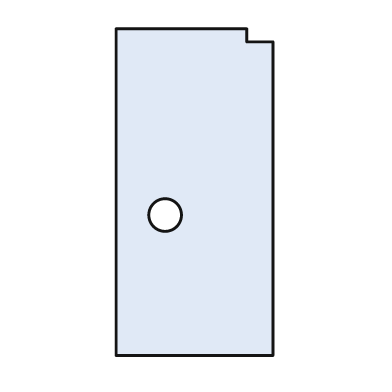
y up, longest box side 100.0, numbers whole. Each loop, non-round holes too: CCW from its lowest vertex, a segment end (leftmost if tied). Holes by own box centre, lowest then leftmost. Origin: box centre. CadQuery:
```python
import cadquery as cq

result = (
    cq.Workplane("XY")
    .moveTo(-24.0, -50.0)
    .lineTo(24.0, -50.0)
    .lineTo(24.0, 46.0)
    .lineTo(16.0, 46.0)
    .lineTo(16.0, 50.0)
    .lineTo(-24.0, 50.0)
    .close()
    .moveTo(-9.0, -7.0)
    .circle(5.0)
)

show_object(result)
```